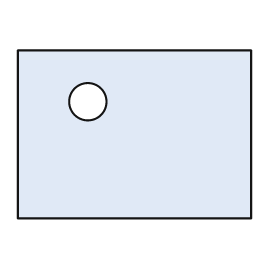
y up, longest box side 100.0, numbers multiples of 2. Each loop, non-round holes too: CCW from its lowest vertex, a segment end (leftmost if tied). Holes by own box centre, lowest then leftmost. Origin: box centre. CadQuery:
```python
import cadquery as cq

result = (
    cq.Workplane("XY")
    .moveTo(-50.0, -36.0)
    .lineTo(50.0, -36.0)
    .lineTo(50.0, 36.0)
    .lineTo(-50.0, 36.0)
    .close()
    .moveTo(-20.0, 14.0)
    .circle(8.0)
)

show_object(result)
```